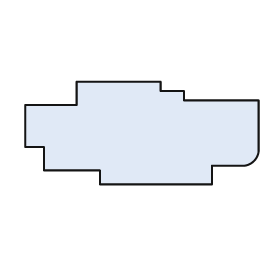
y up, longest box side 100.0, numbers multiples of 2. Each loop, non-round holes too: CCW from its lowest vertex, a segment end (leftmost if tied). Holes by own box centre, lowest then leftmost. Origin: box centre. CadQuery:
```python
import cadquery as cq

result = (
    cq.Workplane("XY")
    .moveTo(-18.0, -22.0)
    .lineTo(30.0, -22.0)
    .lineTo(30.0, -14.0)
    .lineTo(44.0, -14.0)
    .threePointArc((48.0, -12.0), (50.0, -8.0))
    .lineTo(50.0, 14.0)
    .lineTo(18.0, 14.0)
    .lineTo(18.0, 18.0)
    .lineTo(8.0, 18.0)
    .lineTo(8.0, 22.0)
    .lineTo(-28.0, 22.0)
    .lineTo(-28.0, 12.0)
    .lineTo(-50.0, 12.0)
    .lineTo(-50.0, -6.0)
    .lineTo(-42.0, -6.0)
    .lineTo(-42.0, -16.0)
    .lineTo(-18.0, -16.0)
    .close()
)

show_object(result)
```